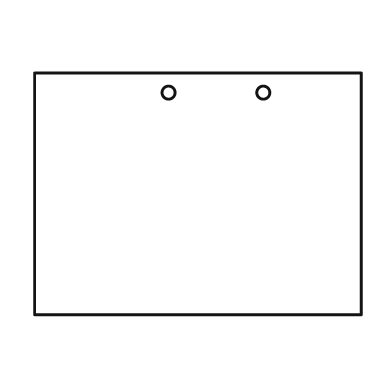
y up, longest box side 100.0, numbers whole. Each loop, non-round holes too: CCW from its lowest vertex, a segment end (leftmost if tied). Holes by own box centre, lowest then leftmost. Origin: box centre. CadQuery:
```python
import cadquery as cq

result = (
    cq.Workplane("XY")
    .moveTo(-50.0, -37.0)
    .lineTo(50.0, -37.0)
    .lineTo(50.0, 37.0)
    .lineTo(-50.0, 37.0)
    .close()
    .moveTo(-9.0, 31.0)
    .circle(2.0)
    .moveTo(20.0, 31.0)
    .circle(2.0)
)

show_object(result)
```